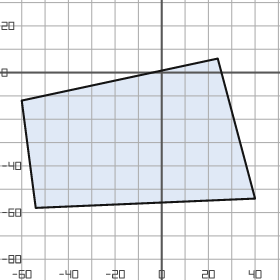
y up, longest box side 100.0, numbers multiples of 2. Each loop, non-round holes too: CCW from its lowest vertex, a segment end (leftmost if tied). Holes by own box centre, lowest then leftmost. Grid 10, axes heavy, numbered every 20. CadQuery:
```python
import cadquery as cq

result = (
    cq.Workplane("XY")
    .moveTo(-54.0, -58.0)
    .lineTo(40.0, -54.0)
    .lineTo(24.0, 6.0)
    .lineTo(-60.0, -12.0)
    .close()
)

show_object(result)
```